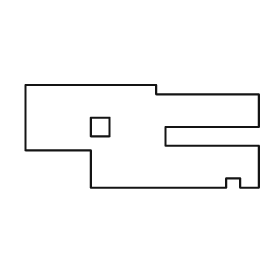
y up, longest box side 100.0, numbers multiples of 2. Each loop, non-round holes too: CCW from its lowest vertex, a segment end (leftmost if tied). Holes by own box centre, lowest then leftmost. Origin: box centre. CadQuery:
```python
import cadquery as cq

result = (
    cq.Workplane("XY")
    .moveTo(-22.0, -22.0)
    .lineTo(36.0, -22.0)
    .lineTo(36.0, -18.0)
    .lineTo(42.0, -18.0)
    .lineTo(42.0, -22.0)
    .lineTo(50.0, -22.0)
    .lineTo(50.0, -4.0)
    .lineTo(10.0, -4.0)
    .lineTo(10.0, 4.0)
    .lineTo(50.0, 4.0)
    .lineTo(50.0, 18.0)
    .lineTo(6.0, 18.0)
    .lineTo(6.0, 22.0)
    .lineTo(-50.0, 22.0)
    .lineTo(-50.0, -6.0)
    .lineTo(-22.0, -6.0)
    .close()
    .moveTo(-22.0, 0.0)
    .lineTo(-14.0, 0.0)
    .lineTo(-14.0, 8.0)
    .lineTo(-22.0, 8.0)
    .close()
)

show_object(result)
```